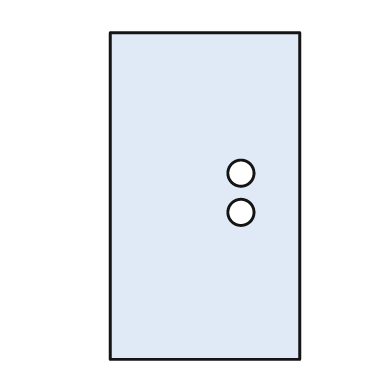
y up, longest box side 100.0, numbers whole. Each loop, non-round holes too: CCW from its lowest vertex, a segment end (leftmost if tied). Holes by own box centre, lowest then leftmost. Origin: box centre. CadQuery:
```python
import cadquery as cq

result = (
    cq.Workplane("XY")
    .moveTo(-29.0, -50.0)
    .lineTo(29.0, -50.0)
    .lineTo(29.0, 50.0)
    .lineTo(-29.0, 50.0)
    .close()
    .moveTo(11.0, -5.0)
    .circle(4.0)
    .moveTo(11.0, 7.0)
    .circle(4.0)
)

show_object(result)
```